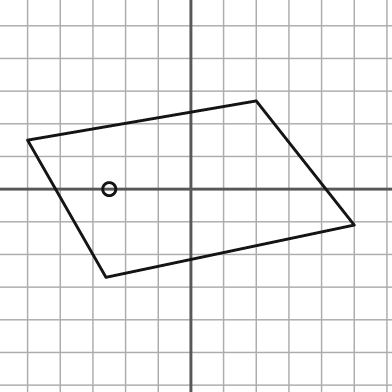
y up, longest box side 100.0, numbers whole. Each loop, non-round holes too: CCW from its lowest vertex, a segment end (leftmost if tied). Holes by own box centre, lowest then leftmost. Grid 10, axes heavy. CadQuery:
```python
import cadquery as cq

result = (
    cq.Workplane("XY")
    .moveTo(-26.0, -27.0)
    .lineTo(50.0, -11.0)
    .lineTo(20.0, 27.0)
    .lineTo(-50.0, 15.0)
    .close()
    .moveTo(-25.0, 0.0)
    .circle(2.0)
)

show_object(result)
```